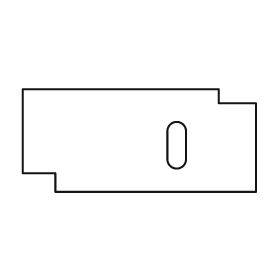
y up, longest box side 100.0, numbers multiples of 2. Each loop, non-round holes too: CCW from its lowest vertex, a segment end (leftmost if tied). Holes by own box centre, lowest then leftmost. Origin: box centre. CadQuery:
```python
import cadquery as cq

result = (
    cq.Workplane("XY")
    .moveTo(-36.0, -22.0)
    .lineTo(50.0, -22.0)
    .lineTo(50.0, 16.0)
    .lineTo(34.0, 16.0)
    .lineTo(34.0, 22.0)
    .lineTo(-50.0, 22.0)
    .lineTo(-50.0, -14.0)
    .lineTo(-36.0, -14.0)
    .close()
    .moveTo(12.0, -8.0)
    .threePointArc((16.0, -12.0), (20.0, -8.0))
    .lineTo(20.0, 4.0)
    .threePointArc((16.0, 8.0), (12.0, 4.0))
    .close()
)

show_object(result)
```